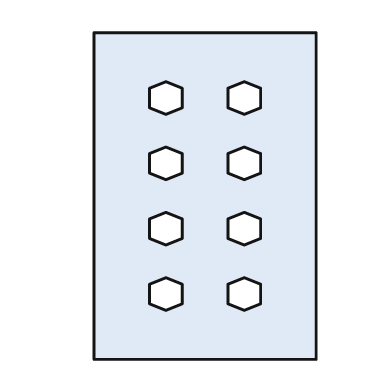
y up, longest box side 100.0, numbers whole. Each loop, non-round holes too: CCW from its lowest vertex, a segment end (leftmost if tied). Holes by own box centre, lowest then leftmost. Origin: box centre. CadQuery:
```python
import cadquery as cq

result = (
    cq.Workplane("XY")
    .moveTo(-34.0, -50.0)
    .lineTo(34.0, -50.0)
    .lineTo(34.0, 50.0)
    .lineTo(-34.0, 50.0)
    .close()
    .moveTo(-12.0, -35.0)
    .lineTo(-7.0, -33.0)
    .lineTo(-7.0, -27.0)
    .lineTo(-12.0, -25.0)
    .lineTo(-17.0, -27.0)
    .lineTo(-17.0, -33.0)
    .close()
    .moveTo(12.0, -35.0)
    .lineTo(17.0, -33.0)
    .lineTo(17.0, -27.0)
    .lineTo(12.0, -25.0)
    .lineTo(7.0, -27.0)
    .lineTo(7.0, -33.0)
    .close()
    .moveTo(-12.0, -15.0)
    .lineTo(-7.0, -13.0)
    .lineTo(-7.0, -7.0)
    .lineTo(-12.0, -5.0)
    .lineTo(-17.0, -7.0)
    .lineTo(-17.0, -13.0)
    .close()
    .moveTo(12.0, -15.0)
    .lineTo(17.0, -13.0)
    .lineTo(17.0, -7.0)
    .lineTo(12.0, -5.0)
    .lineTo(7.0, -7.0)
    .lineTo(7.0, -13.0)
    .close()
    .moveTo(-12.0, 5.0)
    .lineTo(-7.0, 7.0)
    .lineTo(-7.0, 13.0)
    .lineTo(-12.0, 15.0)
    .lineTo(-17.0, 13.0)
    .lineTo(-17.0, 7.0)
    .close()
    .moveTo(12.0, 5.0)
    .lineTo(17.0, 7.0)
    .lineTo(17.0, 13.0)
    .lineTo(12.0, 15.0)
    .lineTo(7.0, 13.0)
    .lineTo(7.0, 7.0)
    .close()
    .moveTo(-12.0, 25.0)
    .lineTo(-7.0, 27.0)
    .lineTo(-7.0, 33.0)
    .lineTo(-12.0, 35.0)
    .lineTo(-17.0, 33.0)
    .lineTo(-17.0, 27.0)
    .close()
    .moveTo(12.0, 25.0)
    .lineTo(17.0, 27.0)
    .lineTo(17.0, 33.0)
    .lineTo(12.0, 35.0)
    .lineTo(7.0, 33.0)
    .lineTo(7.0, 27.0)
    .close()
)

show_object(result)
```